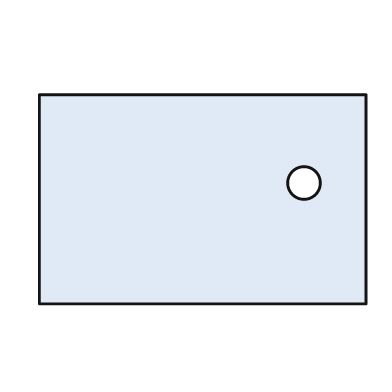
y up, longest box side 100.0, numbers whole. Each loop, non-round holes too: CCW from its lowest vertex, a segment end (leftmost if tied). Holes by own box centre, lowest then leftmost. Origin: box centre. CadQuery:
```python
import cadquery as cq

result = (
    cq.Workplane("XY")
    .moveTo(-50.0, -32.0)
    .lineTo(50.0, -32.0)
    .lineTo(50.0, 32.0)
    .lineTo(-50.0, 32.0)
    .close()
    .moveTo(31.0, 5.0)
    .circle(5.0)
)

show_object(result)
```